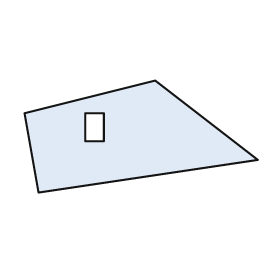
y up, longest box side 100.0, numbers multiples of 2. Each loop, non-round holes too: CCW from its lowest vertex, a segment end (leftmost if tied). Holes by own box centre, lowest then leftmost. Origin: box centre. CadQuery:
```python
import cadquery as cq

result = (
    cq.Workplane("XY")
    .moveTo(-44.0, -24.0)
    .lineTo(50.0, -10.0)
    .lineTo(6.0, 24.0)
    .lineTo(-50.0, 10.0)
    .close()
    .moveTo(-24.0, -2.0)
    .lineTo(-16.0, -2.0)
    .lineTo(-16.0, 10.0)
    .lineTo(-24.0, 10.0)
    .close()
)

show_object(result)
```